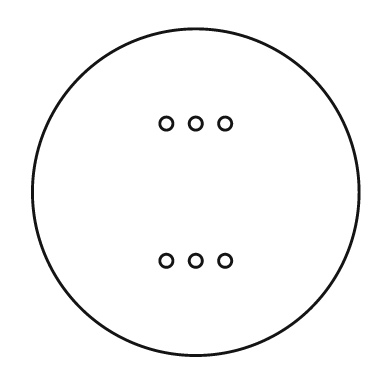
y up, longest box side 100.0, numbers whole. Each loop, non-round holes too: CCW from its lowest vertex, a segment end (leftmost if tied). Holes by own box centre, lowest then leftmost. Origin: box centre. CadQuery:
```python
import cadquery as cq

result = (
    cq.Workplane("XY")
    .moveTo(0.0, 0.0)
    .circle(50.0)
    .moveTo(-9.0, -21.0)
    .circle(2.0)
    .moveTo(0.0, -21.0)
    .circle(2.0)
    .moveTo(9.0, -21.0)
    .circle(2.0)
    .moveTo(-9.0, 21.0)
    .circle(2.0)
    .moveTo(0.0, 21.0)
    .circle(2.0)
    .moveTo(9.0, 21.0)
    .circle(2.0)
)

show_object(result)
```